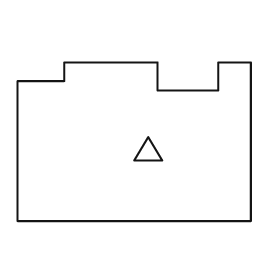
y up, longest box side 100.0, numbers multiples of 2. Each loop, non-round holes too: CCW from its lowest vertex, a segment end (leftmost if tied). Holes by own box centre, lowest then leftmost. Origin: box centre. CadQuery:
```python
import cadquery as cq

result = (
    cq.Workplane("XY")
    .moveTo(-50.0, -34.0)
    .lineTo(50.0, -34.0)
    .lineTo(50.0, 34.0)
    .lineTo(36.0, 34.0)
    .lineTo(36.0, 22.0)
    .lineTo(10.0, 22.0)
    .lineTo(10.0, 34.0)
    .lineTo(-30.0, 34.0)
    .lineTo(-30.0, 26.0)
    .lineTo(-50.0, 26.0)
    .close()
    .moveTo(0.0, -8.0)
    .lineTo(12.0, -8.0)
    .lineTo(6.0, 2.0)
    .close()
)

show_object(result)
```